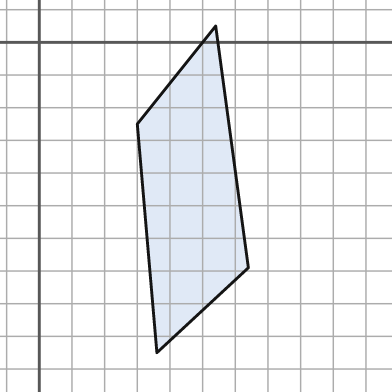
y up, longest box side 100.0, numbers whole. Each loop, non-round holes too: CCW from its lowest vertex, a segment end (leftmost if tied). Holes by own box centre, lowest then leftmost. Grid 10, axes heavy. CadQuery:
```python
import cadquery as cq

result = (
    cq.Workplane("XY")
    .moveTo(36.0, -95.0)
    .lineTo(64.0, -69.0)
    .lineTo(54.0, 5.0)
    .lineTo(30.0, -25.0)
    .close()
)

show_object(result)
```